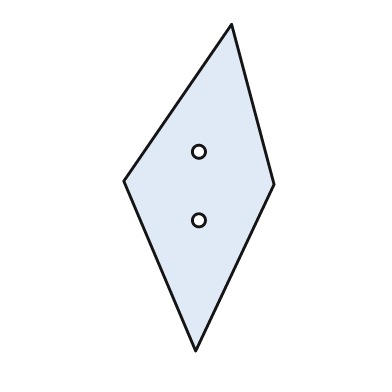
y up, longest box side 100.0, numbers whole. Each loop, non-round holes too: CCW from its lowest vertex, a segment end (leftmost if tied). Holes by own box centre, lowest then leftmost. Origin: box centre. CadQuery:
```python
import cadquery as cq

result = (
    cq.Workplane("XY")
    .moveTo(-1.0, -50.0)
    .lineTo(23.0, 1.0)
    .lineTo(10.0, 50.0)
    .lineTo(-23.0, 2.0)
    .close()
    .moveTo(0.0, -10.0)
    .circle(2.0)
    .moveTo(0.0, 11.0)
    .circle(2.0)
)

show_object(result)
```